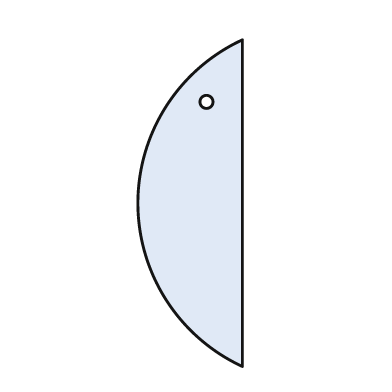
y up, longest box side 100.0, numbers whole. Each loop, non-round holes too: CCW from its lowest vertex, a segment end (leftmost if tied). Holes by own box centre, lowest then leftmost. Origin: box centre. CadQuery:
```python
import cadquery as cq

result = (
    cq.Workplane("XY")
    .moveTo(16.0, -50.0)
    .lineTo(16.0, 50.0)
    .threePointArc((-16.0, 0.0), (16.0, -50.0))
    .close()
    .moveTo(5.0, 31.0)
    .circle(2.0)
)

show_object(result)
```